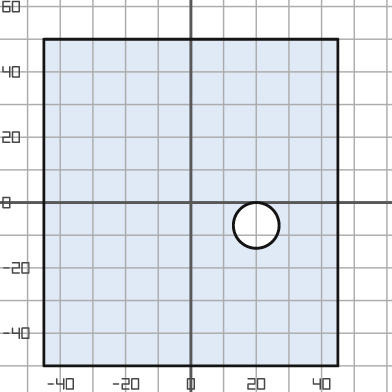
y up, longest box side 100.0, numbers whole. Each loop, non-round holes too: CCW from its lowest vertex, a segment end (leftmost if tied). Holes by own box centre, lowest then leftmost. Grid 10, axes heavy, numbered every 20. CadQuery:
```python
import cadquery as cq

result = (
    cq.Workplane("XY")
    .moveTo(-45.0, -50.0)
    .lineTo(45.0, -50.0)
    .lineTo(45.0, 50.0)
    .lineTo(-45.0, 50.0)
    .close()
    .moveTo(20.0, -7.0)
    .circle(7.0)
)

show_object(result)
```